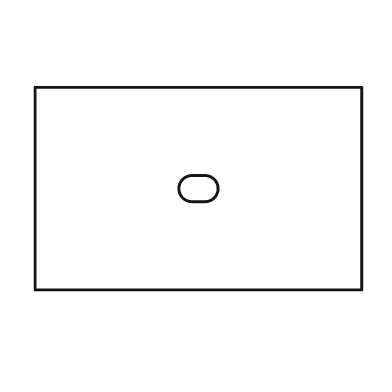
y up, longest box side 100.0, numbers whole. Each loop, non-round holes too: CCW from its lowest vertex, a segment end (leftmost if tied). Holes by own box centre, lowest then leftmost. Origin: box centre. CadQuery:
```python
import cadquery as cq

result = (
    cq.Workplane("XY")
    .moveTo(-50.0, -31.0)
    .lineTo(50.0, -31.0)
    .lineTo(50.0, 31.0)
    .lineTo(-50.0, 31.0)
    .close()
    .moveTo(-2.0, -4.0)
    .lineTo(2.0, -4.0)
    .threePointArc((6.0, 0.0), (2.0, 4.0))
    .lineTo(-2.0, 4.0)
    .threePointArc((-6.0, 0.0), (-2.0, -4.0))
    .close()
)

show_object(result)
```